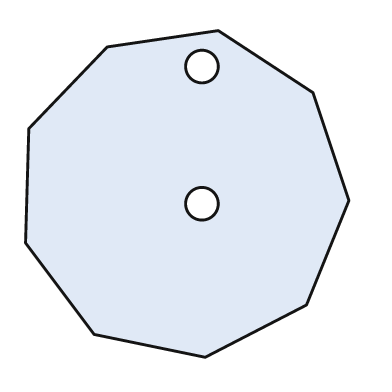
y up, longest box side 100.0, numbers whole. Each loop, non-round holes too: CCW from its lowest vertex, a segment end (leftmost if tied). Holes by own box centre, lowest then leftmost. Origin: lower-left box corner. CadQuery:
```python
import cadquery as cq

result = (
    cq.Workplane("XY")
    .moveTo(55.0, 0.0)
    .lineTo(86.0, 16.0)
    .lineTo(99.0, 48.0)
    .lineTo(88.0, 81.0)
    .lineTo(59.0, 100.0)
    .lineTo(25.0, 95.0)
    .lineTo(1.0, 70.0)
    .lineTo(0.0, 35.0)
    .lineTo(21.0, 7.0)
    .close()
    .moveTo(54.0, 47.0)
    .circle(5.0)
    .moveTo(54.0, 89.0)
    .circle(5.0)
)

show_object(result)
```